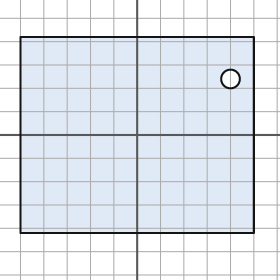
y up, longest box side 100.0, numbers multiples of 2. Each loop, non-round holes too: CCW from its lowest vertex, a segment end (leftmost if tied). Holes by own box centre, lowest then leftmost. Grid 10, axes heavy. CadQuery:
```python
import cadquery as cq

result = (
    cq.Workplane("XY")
    .moveTo(-50.0, -42.0)
    .lineTo(50.0, -42.0)
    .lineTo(50.0, 42.0)
    .lineTo(-50.0, 42.0)
    .close()
    .moveTo(40.0, 24.0)
    .circle(4.0)
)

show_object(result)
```